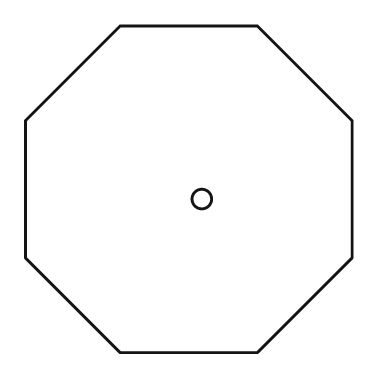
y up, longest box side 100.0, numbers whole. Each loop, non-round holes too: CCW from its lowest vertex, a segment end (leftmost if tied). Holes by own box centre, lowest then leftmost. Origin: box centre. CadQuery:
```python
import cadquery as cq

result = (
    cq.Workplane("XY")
    .moveTo(-21.0, -50.0)
    .lineTo(21.0, -50.0)
    .lineTo(50.0, -21.0)
    .lineTo(50.0, 21.0)
    .lineTo(21.0, 50.0)
    .lineTo(-21.0, 50.0)
    .lineTo(-50.0, 21.0)
    .lineTo(-50.0, -21.0)
    .close()
    .moveTo(4.0, -3.0)
    .circle(3.0)
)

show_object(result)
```